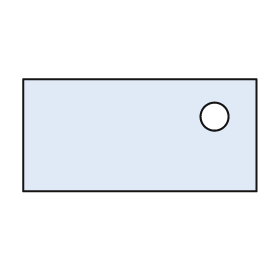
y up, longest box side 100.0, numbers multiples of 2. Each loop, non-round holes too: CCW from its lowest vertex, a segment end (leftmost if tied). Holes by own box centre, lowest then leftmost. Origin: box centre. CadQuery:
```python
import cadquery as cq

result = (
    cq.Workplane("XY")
    .moveTo(-50.0, -24.0)
    .lineTo(50.0, -24.0)
    .lineTo(50.0, 24.0)
    .lineTo(-50.0, 24.0)
    .close()
    .moveTo(32.0, 8.0)
    .circle(6.0)
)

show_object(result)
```